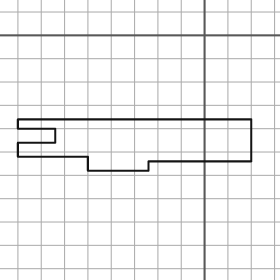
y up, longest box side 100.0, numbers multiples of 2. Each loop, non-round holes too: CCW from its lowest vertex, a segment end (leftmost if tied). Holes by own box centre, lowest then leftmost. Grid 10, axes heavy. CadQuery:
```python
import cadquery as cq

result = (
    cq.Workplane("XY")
    .moveTo(-50.0, -58.0)
    .lineTo(-24.0, -58.0)
    .lineTo(-24.0, -54.0)
    .lineTo(20.0, -54.0)
    .lineTo(20.0, -36.0)
    .lineTo(-80.0, -36.0)
    .lineTo(-80.0, -40.0)
    .lineTo(-64.0, -40.0)
    .lineTo(-64.0, -46.0)
    .lineTo(-80.0, -46.0)
    .lineTo(-80.0, -52.0)
    .lineTo(-50.0, -52.0)
    .close()
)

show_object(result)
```